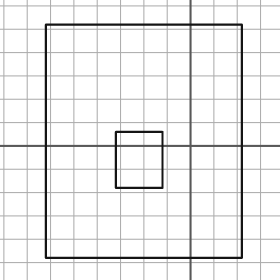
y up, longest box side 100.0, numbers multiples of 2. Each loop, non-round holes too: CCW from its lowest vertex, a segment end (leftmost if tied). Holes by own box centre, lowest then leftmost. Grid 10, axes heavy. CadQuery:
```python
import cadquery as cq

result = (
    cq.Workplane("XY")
    .moveTo(-62.0, -48.0)
    .lineTo(22.0, -48.0)
    .lineTo(22.0, 52.0)
    .lineTo(-62.0, 52.0)
    .close()
    .moveTo(-32.0, -18.0)
    .lineTo(-12.0, -18.0)
    .lineTo(-12.0, 6.0)
    .lineTo(-32.0, 6.0)
    .close()
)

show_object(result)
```